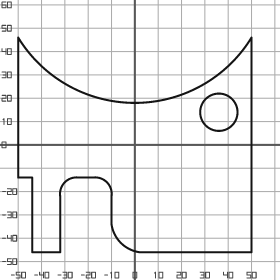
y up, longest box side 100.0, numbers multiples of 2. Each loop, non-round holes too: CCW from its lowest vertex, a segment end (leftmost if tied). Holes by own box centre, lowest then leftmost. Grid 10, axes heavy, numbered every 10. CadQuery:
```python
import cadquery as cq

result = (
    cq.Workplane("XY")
    .moveTo(-44.0, -46.0)
    .lineTo(-32.0, -46.0)
    .lineTo(-32.0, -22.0)
    .threePointArc((-30.0, -16.0), (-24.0, -14.0))
    .lineTo(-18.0, -14.0)
    .threePointArc((-12.0, -16.0), (-10.0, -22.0))
    .lineTo(-10.0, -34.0)
    .threePointArc((-6.0, -42.0), (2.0, -46.0))
    .lineTo(50.0, -46.0)
    .lineTo(50.0, 46.0)
    .threePointArc((0.0, 18.0), (-50.0, 46.0))
    .lineTo(-50.0, -14.0)
    .lineTo(-44.0, -14.0)
    .close()
    .moveTo(36.0, 14.0)
    .circle(8.0)
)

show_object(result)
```